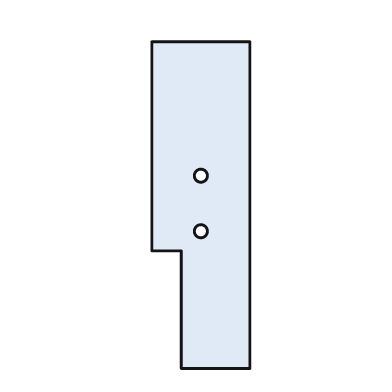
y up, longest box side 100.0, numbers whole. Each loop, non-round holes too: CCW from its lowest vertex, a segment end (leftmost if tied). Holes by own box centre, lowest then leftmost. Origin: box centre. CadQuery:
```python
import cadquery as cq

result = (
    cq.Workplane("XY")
    .moveTo(-6.0, -50.0)
    .lineTo(15.0, -50.0)
    .lineTo(15.0, 50.0)
    .lineTo(-15.0, 50.0)
    .lineTo(-15.0, -14.0)
    .lineTo(-6.0, -14.0)
    .close()
    .moveTo(0.0, -8.0)
    .circle(2.0)
    .moveTo(0.0, 9.0)
    .circle(2.0)
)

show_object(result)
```